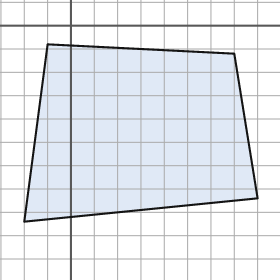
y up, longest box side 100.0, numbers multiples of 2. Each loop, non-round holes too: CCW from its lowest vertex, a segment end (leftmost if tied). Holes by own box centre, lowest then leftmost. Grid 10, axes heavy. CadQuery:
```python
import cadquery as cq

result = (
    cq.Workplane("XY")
    .moveTo(-20.0, -84.0)
    .lineTo(80.0, -74.0)
    .lineTo(70.0, -12.0)
    .lineTo(-10.0, -8.0)
    .close()
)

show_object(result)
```